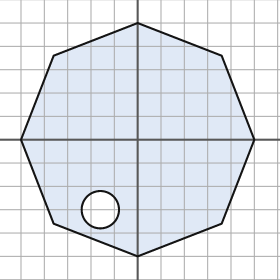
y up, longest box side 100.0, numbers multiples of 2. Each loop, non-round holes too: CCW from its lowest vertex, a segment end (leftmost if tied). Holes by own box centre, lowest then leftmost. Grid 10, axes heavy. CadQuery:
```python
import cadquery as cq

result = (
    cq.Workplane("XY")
    .moveTo(0.0, -50.0)
    .lineTo(36.0, -36.0)
    .lineTo(50.0, 0.0)
    .lineTo(36.0, 36.0)
    .lineTo(0.0, 50.0)
    .lineTo(-36.0, 36.0)
    .lineTo(-50.0, 0.0)
    .lineTo(-36.0, -36.0)
    .close()
    .moveTo(-16.0, -30.0)
    .circle(8.0)
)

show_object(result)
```